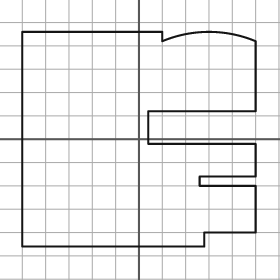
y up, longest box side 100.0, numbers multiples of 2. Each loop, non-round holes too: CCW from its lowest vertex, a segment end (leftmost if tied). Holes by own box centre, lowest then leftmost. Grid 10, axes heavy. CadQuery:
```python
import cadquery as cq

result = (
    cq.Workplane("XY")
    .moveTo(-50.0, -46.0)
    .lineTo(28.0, -46.0)
    .lineTo(28.0, -40.0)
    .lineTo(50.0, -40.0)
    .lineTo(50.0, -20.0)
    .lineTo(26.0, -20.0)
    .lineTo(26.0, -16.0)
    .lineTo(50.0, -16.0)
    .lineTo(50.0, -2.0)
    .lineTo(4.0, -2.0)
    .lineTo(4.0, 12.0)
    .lineTo(50.0, 12.0)
    .lineTo(50.0, 42.0)
    .threePointArc((30.0, 46.0), (10.0, 42.0))
    .lineTo(10.0, 46.0)
    .lineTo(-50.0, 46.0)
    .close()
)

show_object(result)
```